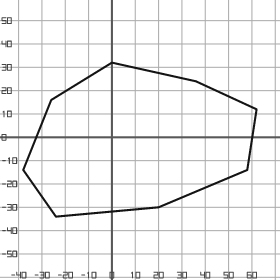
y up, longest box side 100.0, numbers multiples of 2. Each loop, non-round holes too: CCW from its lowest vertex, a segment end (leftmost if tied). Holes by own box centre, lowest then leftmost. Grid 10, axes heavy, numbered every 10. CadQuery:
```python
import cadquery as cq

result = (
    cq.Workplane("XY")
    .moveTo(-24.0, -34.0)
    .lineTo(20.0, -30.0)
    .lineTo(58.0, -14.0)
    .lineTo(62.0, 12.0)
    .lineTo(36.0, 24.0)
    .lineTo(0.0, 32.0)
    .lineTo(-26.0, 16.0)
    .lineTo(-38.0, -14.0)
    .close()
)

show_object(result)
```